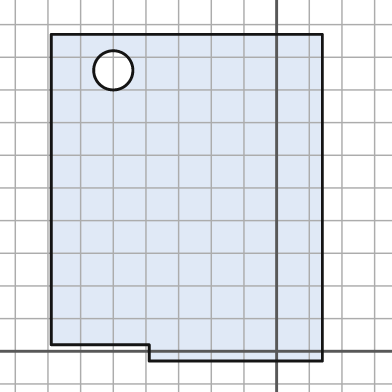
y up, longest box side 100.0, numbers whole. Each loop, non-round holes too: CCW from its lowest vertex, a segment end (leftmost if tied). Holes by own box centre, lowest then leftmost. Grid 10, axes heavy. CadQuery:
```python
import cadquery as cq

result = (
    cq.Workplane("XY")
    .moveTo(-39.0, -3.0)
    .lineTo(14.0, -3.0)
    .lineTo(14.0, 97.0)
    .lineTo(-69.0, 97.0)
    .lineTo(-69.0, 2.0)
    .lineTo(-39.0, 2.0)
    .close()
    .moveTo(-50.0, 86.0)
    .circle(6.0)
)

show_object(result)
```